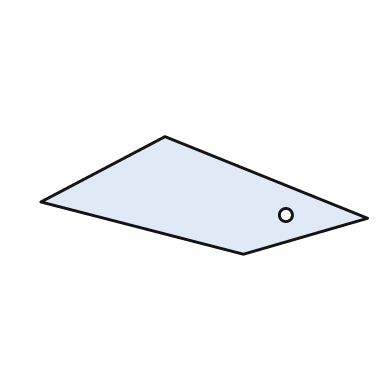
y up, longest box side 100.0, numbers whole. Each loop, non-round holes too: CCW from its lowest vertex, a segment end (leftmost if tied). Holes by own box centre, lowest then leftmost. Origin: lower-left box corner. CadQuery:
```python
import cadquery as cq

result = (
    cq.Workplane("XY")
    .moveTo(62.0, 0.0)
    .lineTo(100.0, 11.0)
    .lineTo(38.0, 36.0)
    .lineTo(0.0, 16.0)
    .close()
    .moveTo(75.0, 12.0)
    .circle(2.0)
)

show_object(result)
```